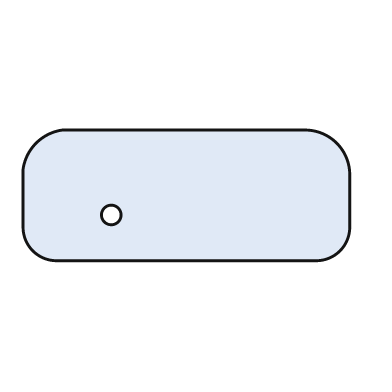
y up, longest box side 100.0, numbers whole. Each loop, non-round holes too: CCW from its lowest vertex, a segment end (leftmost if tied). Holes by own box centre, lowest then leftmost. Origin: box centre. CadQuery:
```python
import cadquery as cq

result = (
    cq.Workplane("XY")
    .moveTo(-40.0, -20.0)
    .lineTo(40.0, -20.0)
    .threePointArc((47.0, -17.0), (50.0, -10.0))
    .lineTo(50.0, 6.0)
    .threePointArc((46.0, 16.0), (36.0, 20.0))
    .lineTo(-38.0, 20.0)
    .threePointArc((-46.0, 16.0), (-50.0, 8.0))
    .lineTo(-50.0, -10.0)
    .threePointArc((-47.0, -17.0), (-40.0, -20.0))
    .close()
    .moveTo(-23.0, -6.0)
    .circle(3.0)
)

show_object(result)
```